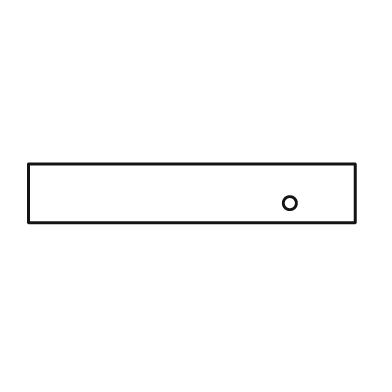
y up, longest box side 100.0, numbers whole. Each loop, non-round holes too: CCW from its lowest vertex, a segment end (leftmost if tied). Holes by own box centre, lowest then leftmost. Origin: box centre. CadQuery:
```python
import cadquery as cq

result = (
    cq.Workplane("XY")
    .moveTo(-50.0, -9.0)
    .lineTo(50.0, -9.0)
    .lineTo(50.0, 9.0)
    .lineTo(-50.0, 9.0)
    .close()
    .moveTo(30.0, -3.0)
    .circle(2.0)
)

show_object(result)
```